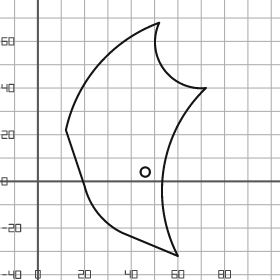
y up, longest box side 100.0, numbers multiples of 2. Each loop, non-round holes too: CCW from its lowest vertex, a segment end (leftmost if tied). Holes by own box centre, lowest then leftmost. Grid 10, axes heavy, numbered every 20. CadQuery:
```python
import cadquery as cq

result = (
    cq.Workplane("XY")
    .moveTo(60.0, -32.0)
    .threePointArc((54.0, 6.0), (72.0, 40.0))
    .threePointArc((54.0, 48.0), (52.0, 68.0))
    .threePointArc((26.0, 50.0), (12.0, 22.0))
    .lineTo(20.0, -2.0)
    .threePointArc((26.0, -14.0), (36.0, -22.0))
    .close()
    .moveTo(46.0, 4.0)
    .circle(2.0)
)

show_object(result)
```